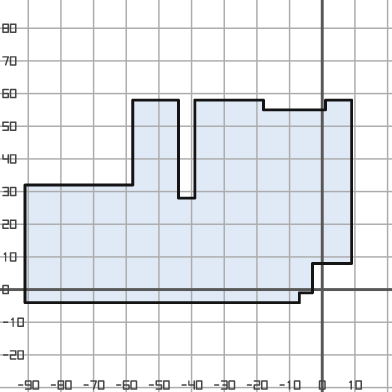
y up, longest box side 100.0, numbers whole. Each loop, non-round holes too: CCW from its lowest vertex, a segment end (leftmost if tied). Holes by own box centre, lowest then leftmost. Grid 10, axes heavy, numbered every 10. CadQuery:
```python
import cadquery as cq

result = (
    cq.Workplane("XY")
    .moveTo(-91.0, -4.0)
    .lineTo(-7.0, -4.0)
    .lineTo(-7.0, -1.0)
    .lineTo(-3.0, -1.0)
    .lineTo(-3.0, 8.0)
    .lineTo(9.0, 8.0)
    .lineTo(9.0, 58.0)
    .lineTo(1.0, 58.0)
    .lineTo(1.0, 55.0)
    .lineTo(-18.0, 55.0)
    .lineTo(-18.0, 58.0)
    .lineTo(-39.0, 58.0)
    .lineTo(-39.0, 28.0)
    .lineTo(-44.0, 28.0)
    .lineTo(-44.0, 58.0)
    .lineTo(-58.0, 58.0)
    .lineTo(-58.0, 32.0)
    .lineTo(-91.0, 32.0)
    .close()
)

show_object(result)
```